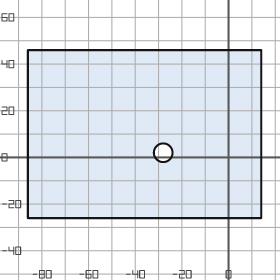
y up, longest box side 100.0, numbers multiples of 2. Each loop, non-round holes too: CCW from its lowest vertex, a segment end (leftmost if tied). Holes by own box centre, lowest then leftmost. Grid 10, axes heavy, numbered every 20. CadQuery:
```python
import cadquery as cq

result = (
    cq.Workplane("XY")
    .moveTo(-86.0, -26.0)
    .lineTo(14.0, -26.0)
    .lineTo(14.0, 46.0)
    .lineTo(-86.0, 46.0)
    .close()
    .moveTo(-28.0, 2.0)
    .circle(4.0)
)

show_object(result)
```